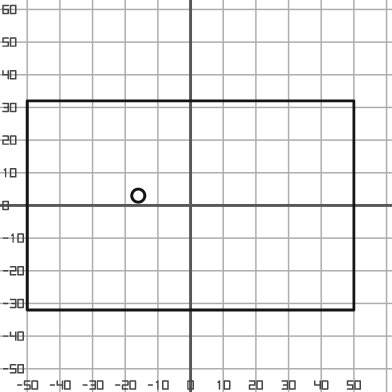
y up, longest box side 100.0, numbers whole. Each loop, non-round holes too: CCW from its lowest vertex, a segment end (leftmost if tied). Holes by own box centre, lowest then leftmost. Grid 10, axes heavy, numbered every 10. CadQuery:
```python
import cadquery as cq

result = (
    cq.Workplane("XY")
    .moveTo(-50.0, -32.0)
    .lineTo(50.0, -32.0)
    .lineTo(50.0, 32.0)
    .lineTo(-50.0, 32.0)
    .close()
    .moveTo(-16.0, 3.0)
    .circle(2.0)
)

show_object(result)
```